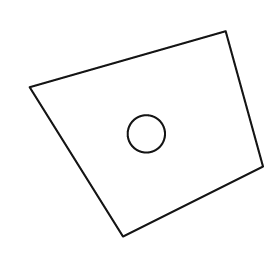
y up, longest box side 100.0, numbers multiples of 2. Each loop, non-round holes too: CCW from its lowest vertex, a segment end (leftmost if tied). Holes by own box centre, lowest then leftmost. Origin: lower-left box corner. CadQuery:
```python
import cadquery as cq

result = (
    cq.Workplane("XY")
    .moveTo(40.0, 0.0)
    .lineTo(100.0, 30.0)
    .lineTo(84.0, 88.0)
    .lineTo(0.0, 64.0)
    .close()
    .moveTo(50.0, 44.0)
    .circle(8.0)
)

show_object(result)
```